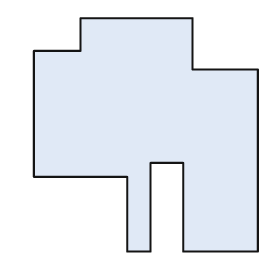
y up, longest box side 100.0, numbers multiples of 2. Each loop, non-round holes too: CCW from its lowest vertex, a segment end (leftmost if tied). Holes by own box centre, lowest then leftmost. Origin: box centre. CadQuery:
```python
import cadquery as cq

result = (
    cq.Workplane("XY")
    .moveTo(-8.0, -50.0)
    .lineTo(2.0, -50.0)
    .lineTo(2.0, -12.0)
    .lineTo(16.0, -12.0)
    .lineTo(16.0, -50.0)
    .lineTo(48.0, -50.0)
    .lineTo(48.0, 28.0)
    .lineTo(20.0, 28.0)
    .lineTo(20.0, 50.0)
    .lineTo(-28.0, 50.0)
    .lineTo(-28.0, 36.0)
    .lineTo(-48.0, 36.0)
    .lineTo(-48.0, -18.0)
    .lineTo(-8.0, -18.0)
    .close()
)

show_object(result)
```